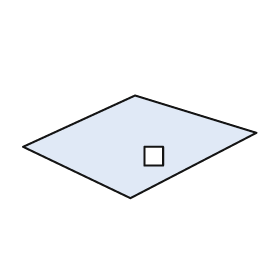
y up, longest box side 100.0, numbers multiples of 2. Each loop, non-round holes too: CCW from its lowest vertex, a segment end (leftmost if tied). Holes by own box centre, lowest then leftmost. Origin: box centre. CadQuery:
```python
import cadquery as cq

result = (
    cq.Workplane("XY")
    .moveTo(-4.0, -22.0)
    .lineTo(50.0, 6.0)
    .lineTo(-2.0, 22.0)
    .lineTo(-50.0, 0.0)
    .close()
    .moveTo(2.0, -8.0)
    .lineTo(10.0, -8.0)
    .lineTo(10.0, 0.0)
    .lineTo(2.0, 0.0)
    .close()
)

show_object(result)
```